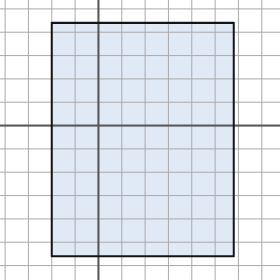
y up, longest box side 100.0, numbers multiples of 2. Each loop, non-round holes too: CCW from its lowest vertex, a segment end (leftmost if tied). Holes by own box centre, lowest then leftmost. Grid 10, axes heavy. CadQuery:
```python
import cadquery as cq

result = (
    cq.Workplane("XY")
    .moveTo(-20.0, -56.0)
    .lineTo(58.0, -56.0)
    .lineTo(58.0, 44.0)
    .lineTo(-20.0, 44.0)
    .close()
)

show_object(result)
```